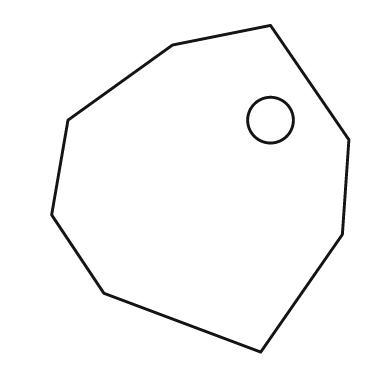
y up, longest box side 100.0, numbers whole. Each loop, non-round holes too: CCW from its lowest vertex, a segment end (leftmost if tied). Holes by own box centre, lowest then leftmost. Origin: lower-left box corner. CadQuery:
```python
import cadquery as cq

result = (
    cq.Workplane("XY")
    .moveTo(64.0, 0.0)
    .lineTo(89.0, 36.0)
    .lineTo(91.0, 65.0)
    .lineTo(67.0, 100.0)
    .lineTo(37.0, 94.0)
    .lineTo(5.0, 71.0)
    .lineTo(0.0, 42.0)
    .lineTo(16.0, 18.0)
    .close()
    .moveTo(67.0, 71.0)
    .circle(7.0)
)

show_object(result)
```